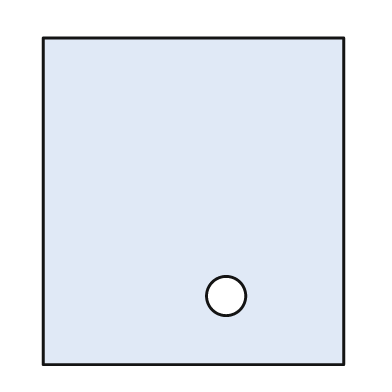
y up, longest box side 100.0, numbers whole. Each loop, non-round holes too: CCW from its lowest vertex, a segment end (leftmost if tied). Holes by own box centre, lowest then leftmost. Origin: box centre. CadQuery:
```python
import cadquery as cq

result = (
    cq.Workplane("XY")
    .moveTo(-46.0, -50.0)
    .lineTo(46.0, -50.0)
    .lineTo(46.0, 50.0)
    .lineTo(-46.0, 50.0)
    .close()
    .moveTo(10.0, -29.0)
    .circle(6.0)
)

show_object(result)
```